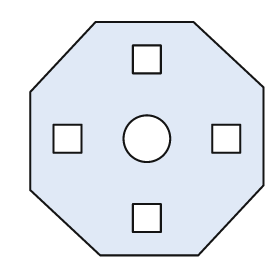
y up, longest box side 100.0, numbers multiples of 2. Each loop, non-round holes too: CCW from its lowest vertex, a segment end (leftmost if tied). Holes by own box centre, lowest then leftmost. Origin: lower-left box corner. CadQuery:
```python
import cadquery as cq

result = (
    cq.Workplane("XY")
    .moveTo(30.0, 0.0)
    .lineTo(72.0, 0.0)
    .lineTo(100.0, 30.0)
    .lineTo(100.0, 72.0)
    .lineTo(70.0, 100.0)
    .lineTo(28.0, 100.0)
    .lineTo(0.0, 70.0)
    .lineTo(0.0, 28.0)
    .close()
    .moveTo(44.0, 10.0)
    .lineTo(56.0, 10.0)
    .lineTo(56.0, 22.0)
    .lineTo(44.0, 22.0)
    .close()
    .moveTo(10.0, 44.0)
    .lineTo(22.0, 44.0)
    .lineTo(22.0, 56.0)
    .lineTo(10.0, 56.0)
    .close()
    .moveTo(50.0, 50.0)
    .circle(10.0)
    .moveTo(78.0, 44.0)
    .lineTo(90.0, 44.0)
    .lineTo(90.0, 56.0)
    .lineTo(78.0, 56.0)
    .close()
    .moveTo(44.0, 78.0)
    .lineTo(56.0, 78.0)
    .lineTo(56.0, 90.0)
    .lineTo(44.0, 90.0)
    .close()
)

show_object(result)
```